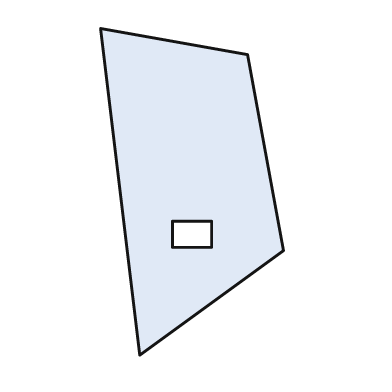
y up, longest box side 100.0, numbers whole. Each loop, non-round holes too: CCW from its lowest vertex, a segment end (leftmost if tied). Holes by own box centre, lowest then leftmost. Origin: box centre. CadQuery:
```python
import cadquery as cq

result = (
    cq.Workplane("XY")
    .moveTo(-16.0, -50.0)
    .lineTo(28.0, -18.0)
    .lineTo(17.0, 42.0)
    .lineTo(-28.0, 50.0)
    .close()
    .moveTo(-6.0, -17.0)
    .lineTo(6.0, -17.0)
    .lineTo(6.0, -9.0)
    .lineTo(-6.0, -9.0)
    .close()
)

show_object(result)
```